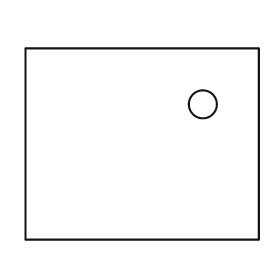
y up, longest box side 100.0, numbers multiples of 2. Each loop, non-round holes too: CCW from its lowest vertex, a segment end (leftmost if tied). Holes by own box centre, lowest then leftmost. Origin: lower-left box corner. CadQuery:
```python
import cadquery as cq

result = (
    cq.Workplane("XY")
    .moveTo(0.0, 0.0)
    .lineTo(100.0, 0.0)
    .lineTo(100.0, 82.0)
    .lineTo(0.0, 82.0)
    .close()
    .moveTo(76.0, 58.0)
    .circle(6.0)
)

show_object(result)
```